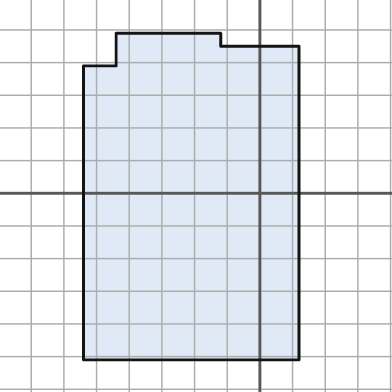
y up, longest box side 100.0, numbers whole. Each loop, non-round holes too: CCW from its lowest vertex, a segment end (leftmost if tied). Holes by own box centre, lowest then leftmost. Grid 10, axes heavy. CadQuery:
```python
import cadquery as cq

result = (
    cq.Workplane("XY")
    .moveTo(-54.0, -51.0)
    .lineTo(12.0, -51.0)
    .lineTo(12.0, 45.0)
    .lineTo(-12.0, 45.0)
    .lineTo(-12.0, 49.0)
    .lineTo(-44.0, 49.0)
    .lineTo(-44.0, 39.0)
    .lineTo(-54.0, 39.0)
    .close()
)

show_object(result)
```